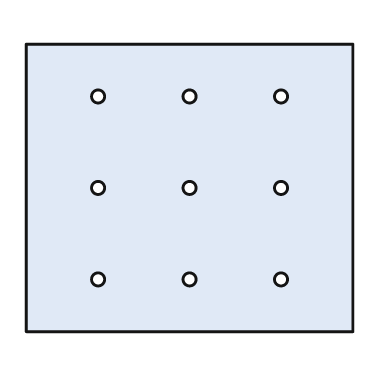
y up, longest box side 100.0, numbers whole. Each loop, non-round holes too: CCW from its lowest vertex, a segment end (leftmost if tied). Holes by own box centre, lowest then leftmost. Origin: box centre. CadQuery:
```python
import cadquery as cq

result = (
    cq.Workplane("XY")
    .moveTo(-50.0, -44.0)
    .lineTo(50.0, -44.0)
    .lineTo(50.0, 44.0)
    .lineTo(-50.0, 44.0)
    .close()
    .moveTo(-28.0, -28.0)
    .circle(2.0)
    .moveTo(0.0, -28.0)
    .circle(2.0)
    .moveTo(28.0, -28.0)
    .circle(2.0)
    .moveTo(-28.0, 0.0)
    .circle(2.0)
    .moveTo(0.0, 0.0)
    .circle(2.0)
    .moveTo(28.0, 0.0)
    .circle(2.0)
    .moveTo(-28.0, 28.0)
    .circle(2.0)
    .moveTo(0.0, 28.0)
    .circle(2.0)
    .moveTo(28.0, 28.0)
    .circle(2.0)
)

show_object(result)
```